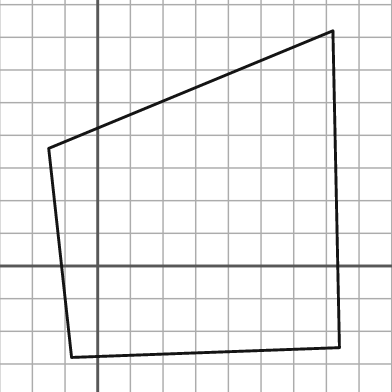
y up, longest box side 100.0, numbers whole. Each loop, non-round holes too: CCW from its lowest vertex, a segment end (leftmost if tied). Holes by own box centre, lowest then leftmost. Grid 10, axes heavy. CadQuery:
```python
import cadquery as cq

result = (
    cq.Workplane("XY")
    .moveTo(-8.0, -28.0)
    .lineTo(74.0, -25.0)
    .lineTo(72.0, 72.0)
    .lineTo(-15.0, 36.0)
    .close()
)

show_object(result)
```